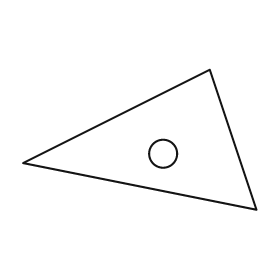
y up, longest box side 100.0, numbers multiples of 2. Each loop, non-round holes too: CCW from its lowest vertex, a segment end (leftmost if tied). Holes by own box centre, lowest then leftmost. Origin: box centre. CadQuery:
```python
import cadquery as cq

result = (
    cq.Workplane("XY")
    .moveTo(50.0, -30.0)
    .lineTo(30.0, 30.0)
    .lineTo(-50.0, -10.0)
    .close()
    .moveTo(10.0, -6.0)
    .circle(6.0)
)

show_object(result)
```